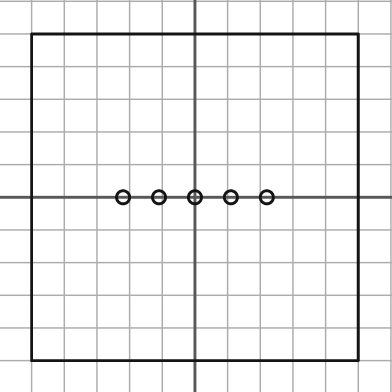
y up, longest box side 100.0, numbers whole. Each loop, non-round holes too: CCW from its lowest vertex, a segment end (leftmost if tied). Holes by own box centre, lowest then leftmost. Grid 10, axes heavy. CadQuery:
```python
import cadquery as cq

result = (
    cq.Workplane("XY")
    .moveTo(-50.0, -50.0)
    .lineTo(50.0, -50.0)
    .lineTo(50.0, 50.0)
    .lineTo(-50.0, 50.0)
    .close()
    .moveTo(-22.0, 0.0)
    .circle(2.0)
    .moveTo(-11.0, 0.0)
    .circle(2.0)
    .moveTo(0.0, 0.0)
    .circle(2.0)
    .moveTo(11.0, 0.0)
    .circle(2.0)
    .moveTo(22.0, 0.0)
    .circle(2.0)
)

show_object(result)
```